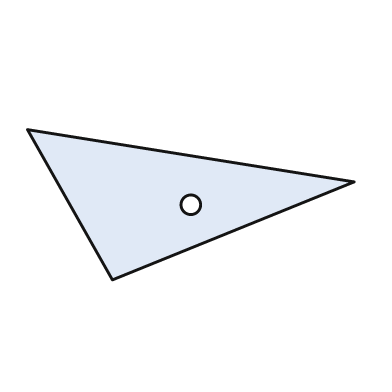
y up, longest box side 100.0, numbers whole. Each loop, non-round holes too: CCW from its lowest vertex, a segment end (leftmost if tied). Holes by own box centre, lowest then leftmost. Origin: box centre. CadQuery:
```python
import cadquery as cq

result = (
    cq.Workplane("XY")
    .moveTo(-24.0, -23.0)
    .lineTo(50.0, 7.0)
    .lineTo(-50.0, 23.0)
    .close()
    .moveTo(0.0, 0.0)
    .circle(3.0)
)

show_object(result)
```